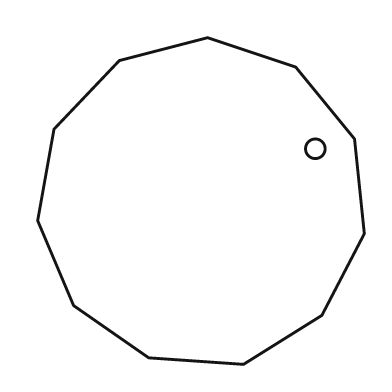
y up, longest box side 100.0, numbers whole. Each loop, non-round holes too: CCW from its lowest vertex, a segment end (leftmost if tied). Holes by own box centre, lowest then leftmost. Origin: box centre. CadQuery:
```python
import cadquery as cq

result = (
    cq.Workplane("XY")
    .moveTo(13.0, -50.0)
    .lineTo(37.0, -35.0)
    .lineTo(50.0, -10.0)
    .lineTo(47.0, 19.0)
    .lineTo(29.0, 41.0)
    .lineTo(2.0, 50.0)
    .lineTo(-25.0, 43.0)
    .lineTo(-45.0, 22.0)
    .lineTo(-50.0, -6.0)
    .lineTo(-39.0, -32.0)
    .lineTo(-16.0, -48.0)
    .close()
    .moveTo(35.0, 16.0)
    .circle(3.0)
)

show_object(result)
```